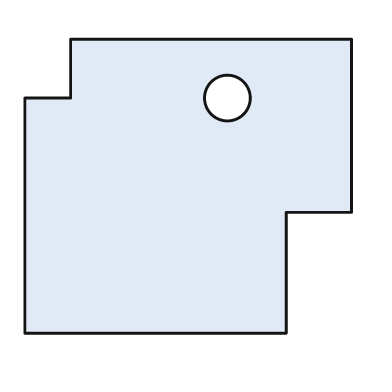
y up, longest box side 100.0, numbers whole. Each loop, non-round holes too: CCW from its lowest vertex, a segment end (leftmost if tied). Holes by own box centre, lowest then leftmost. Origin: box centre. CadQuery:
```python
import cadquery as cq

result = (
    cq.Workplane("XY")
    .moveTo(-50.0, -45.0)
    .lineTo(30.0, -45.0)
    .lineTo(30.0, -8.0)
    .lineTo(50.0, -8.0)
    .lineTo(50.0, 45.0)
    .lineTo(-36.0, 45.0)
    .lineTo(-36.0, 27.0)
    .lineTo(-50.0, 27.0)
    .close()
    .moveTo(12.0, 27.0)
    .circle(7.0)
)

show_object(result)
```